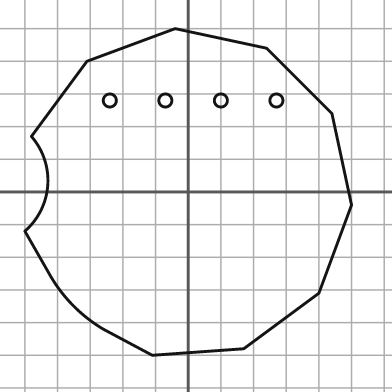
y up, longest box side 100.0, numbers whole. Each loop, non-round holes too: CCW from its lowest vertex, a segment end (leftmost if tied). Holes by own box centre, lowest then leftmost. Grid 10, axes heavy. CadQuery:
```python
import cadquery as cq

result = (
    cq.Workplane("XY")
    .moveTo(-11.0, -50.0)
    .lineTo(17.0, -48.0)
    .lineTo(40.0, -31.0)
    .lineTo(50.0, -4.0)
    .lineTo(44.0, 24.0)
    .lineTo(24.0, 44.0)
    .lineTo(-4.0, 50.0)
    .lineTo(-31.0, 40.0)
    .lineTo(-48.0, 17.0)
    .threePointArc((-43.0, 2.0), (-50.0, -12.0))
    .lineTo(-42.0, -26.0)
    .threePointArc((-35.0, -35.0), (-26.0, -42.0))
    .close()
    .moveTo(-24.0, 28.0)
    .circle(2.0)
    .moveTo(-7.0, 28.0)
    .circle(2.0)
    .moveTo(10.0, 28.0)
    .circle(2.0)
    .moveTo(27.0, 28.0)
    .circle(2.0)
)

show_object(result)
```